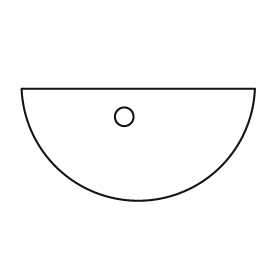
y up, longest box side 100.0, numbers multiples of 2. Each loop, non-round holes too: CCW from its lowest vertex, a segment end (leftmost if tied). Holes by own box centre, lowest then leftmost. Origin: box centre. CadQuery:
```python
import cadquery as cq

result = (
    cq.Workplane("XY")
    .moveTo(-50.0, 24.0)
    .threePointArc((0.0, -24.0), (50.0, 24.0))
    .close()
    .moveTo(-6.0, 12.0)
    .circle(4.0)
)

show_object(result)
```